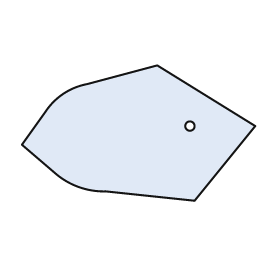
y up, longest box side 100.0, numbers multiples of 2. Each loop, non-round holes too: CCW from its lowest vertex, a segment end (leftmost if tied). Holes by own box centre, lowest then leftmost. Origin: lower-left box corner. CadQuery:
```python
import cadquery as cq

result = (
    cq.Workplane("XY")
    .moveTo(74.0, 0.0)
    .lineTo(100.0, 32.0)
    .lineTo(58.0, 58.0)
    .lineTo(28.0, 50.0)
    .threePointArc((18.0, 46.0), (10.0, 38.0))
    .lineTo(0.0, 24.0)
    .lineTo(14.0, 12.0)
    .threePointArc((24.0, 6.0), (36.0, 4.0))
    .close()
    .moveTo(72.0, 32.0)
    .circle(2.0)
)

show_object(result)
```